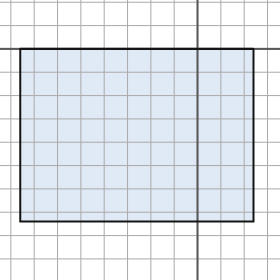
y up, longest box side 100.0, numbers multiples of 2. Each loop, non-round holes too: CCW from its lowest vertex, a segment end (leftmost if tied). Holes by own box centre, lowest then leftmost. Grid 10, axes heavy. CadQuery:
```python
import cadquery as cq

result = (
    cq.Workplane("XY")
    .moveTo(-76.0, -74.0)
    .lineTo(24.0, -74.0)
    .lineTo(24.0, 0.0)
    .lineTo(-76.0, 0.0)
    .close()
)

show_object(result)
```